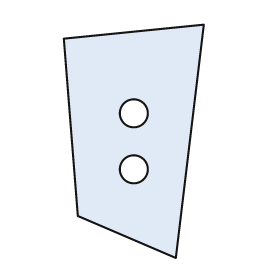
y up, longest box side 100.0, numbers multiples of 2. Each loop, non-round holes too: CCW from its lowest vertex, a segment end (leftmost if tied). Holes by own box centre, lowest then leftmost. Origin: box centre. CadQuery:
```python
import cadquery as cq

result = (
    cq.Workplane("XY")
    .moveTo(18.0, -50.0)
    .lineTo(30.0, 50.0)
    .lineTo(-30.0, 44.0)
    .lineTo(-24.0, -32.0)
    .close()
    .moveTo(0.0, -12.0)
    .circle(6.0)
    .moveTo(0.0, 12.0)
    .circle(6.0)
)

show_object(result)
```